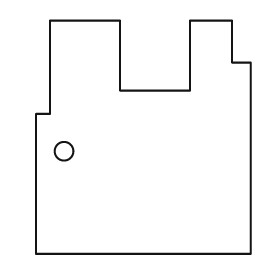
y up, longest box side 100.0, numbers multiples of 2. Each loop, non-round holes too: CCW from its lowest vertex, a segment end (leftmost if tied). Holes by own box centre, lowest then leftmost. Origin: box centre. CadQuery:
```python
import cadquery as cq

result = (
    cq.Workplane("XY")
    .moveTo(-46.0, -50.0)
    .lineTo(46.0, -50.0)
    .lineTo(46.0, 32.0)
    .lineTo(38.0, 32.0)
    .lineTo(38.0, 50.0)
    .lineTo(20.0, 50.0)
    .lineTo(20.0, 20.0)
    .lineTo(-10.0, 20.0)
    .lineTo(-10.0, 50.0)
    .lineTo(-40.0, 50.0)
    .lineTo(-40.0, 10.0)
    .lineTo(-46.0, 10.0)
    .close()
    .moveTo(-34.0, -6.0)
    .circle(4.0)
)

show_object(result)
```